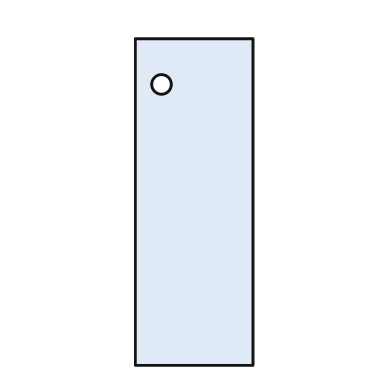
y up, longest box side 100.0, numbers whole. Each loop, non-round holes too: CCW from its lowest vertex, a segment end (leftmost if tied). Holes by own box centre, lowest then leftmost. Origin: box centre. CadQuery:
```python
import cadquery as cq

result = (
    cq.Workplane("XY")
    .moveTo(-18.0, -50.0)
    .lineTo(18.0, -50.0)
    .lineTo(18.0, 50.0)
    .lineTo(-18.0, 50.0)
    .close()
    .moveTo(-10.0, 36.0)
    .circle(3.0)
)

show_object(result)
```